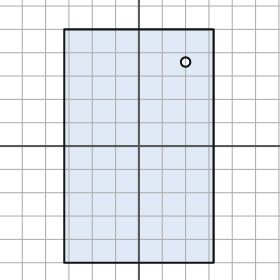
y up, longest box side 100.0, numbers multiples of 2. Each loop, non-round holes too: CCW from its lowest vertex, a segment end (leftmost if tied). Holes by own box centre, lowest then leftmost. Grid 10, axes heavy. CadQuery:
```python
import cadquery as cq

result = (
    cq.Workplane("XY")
    .moveTo(-32.0, -50.0)
    .lineTo(32.0, -50.0)
    .lineTo(32.0, 50.0)
    .lineTo(-32.0, 50.0)
    .close()
    .moveTo(20.0, 36.0)
    .circle(2.0)
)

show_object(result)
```